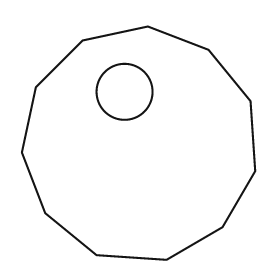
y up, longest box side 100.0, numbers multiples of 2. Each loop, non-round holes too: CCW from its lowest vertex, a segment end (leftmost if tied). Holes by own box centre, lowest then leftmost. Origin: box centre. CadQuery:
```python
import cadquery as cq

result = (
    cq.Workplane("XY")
    .moveTo(12.0, -50.0)
    .lineTo(36.0, -36.0)
    .lineTo(50.0, -12.0)
    .lineTo(48.0, 18.0)
    .lineTo(30.0, 40.0)
    .lineTo(4.0, 50.0)
    .lineTo(-24.0, 44.0)
    .lineTo(-44.0, 24.0)
    .lineTo(-50.0, -4.0)
    .lineTo(-40.0, -30.0)
    .lineTo(-18.0, -48.0)
    .close()
    .moveTo(-6.0, 22.0)
    .circle(12.0)
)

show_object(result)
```